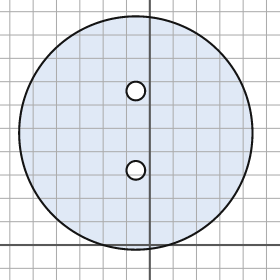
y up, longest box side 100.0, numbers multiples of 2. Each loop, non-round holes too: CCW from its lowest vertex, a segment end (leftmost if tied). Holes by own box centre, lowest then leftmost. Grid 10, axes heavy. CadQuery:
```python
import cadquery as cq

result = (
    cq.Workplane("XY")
    .moveTo(-6.0, 48.0)
    .circle(50.0)
    .moveTo(-6.0, 32.0)
    .circle(4.0)
    .moveTo(-6.0, 66.0)
    .circle(4.0)
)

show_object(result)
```